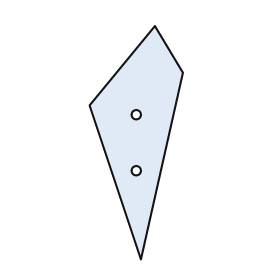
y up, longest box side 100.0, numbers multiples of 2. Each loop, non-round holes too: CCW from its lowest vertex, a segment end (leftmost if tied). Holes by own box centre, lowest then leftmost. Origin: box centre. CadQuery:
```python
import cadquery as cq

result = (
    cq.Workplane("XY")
    .moveTo(2.0, -50.0)
    .lineTo(20.0, 30.0)
    .lineTo(8.0, 50.0)
    .lineTo(-20.0, 16.0)
    .close()
    .moveTo(0.0, -12.0)
    .circle(2.0)
    .moveTo(0.0, 12.0)
    .circle(2.0)
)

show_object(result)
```